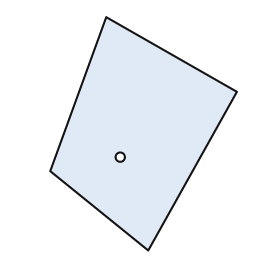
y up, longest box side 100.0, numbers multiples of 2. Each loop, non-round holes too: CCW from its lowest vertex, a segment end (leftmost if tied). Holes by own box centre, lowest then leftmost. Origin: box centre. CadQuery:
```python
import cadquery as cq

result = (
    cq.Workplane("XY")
    .moveTo(2.0, -50.0)
    .lineTo(40.0, 18.0)
    .lineTo(-16.0, 50.0)
    .lineTo(-40.0, -16.0)
    .close()
    .moveTo(-10.0, -10.0)
    .circle(2.0)
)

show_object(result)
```